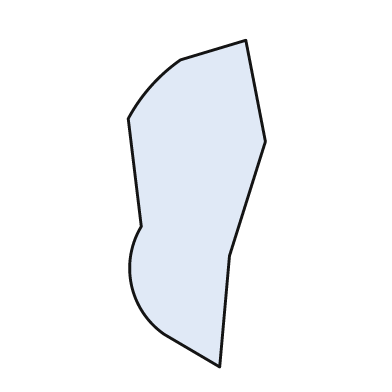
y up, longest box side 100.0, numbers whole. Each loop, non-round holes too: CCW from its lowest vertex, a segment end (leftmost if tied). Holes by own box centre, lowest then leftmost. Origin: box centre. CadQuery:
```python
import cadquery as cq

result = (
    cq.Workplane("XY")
    .moveTo(7.0, -50.0)
    .lineTo(10.0, -16.0)
    .lineTo(21.0, 19.0)
    .lineTo(15.0, 50.0)
    .lineTo(-5.0, 44.0)
    .threePointArc((-14.0, 36.0), (-21.0, 26.0))
    .lineTo(-17.0, -7.0)
    .threePointArc((-20.0, -25.0), (-10.0, -40.0))
    .close()
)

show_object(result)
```